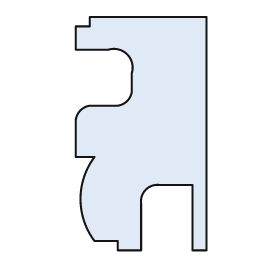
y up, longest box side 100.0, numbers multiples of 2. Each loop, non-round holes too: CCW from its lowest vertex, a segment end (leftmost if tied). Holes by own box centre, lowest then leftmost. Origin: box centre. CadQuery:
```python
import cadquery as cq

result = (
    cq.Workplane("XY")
    .moveTo(-10.0, -50.0)
    .lineTo(0.0, -50.0)
    .lineTo(0.0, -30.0)
    .threePointArc((2.0, -24.0), (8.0, -22.0))
    .lineTo(22.0, -22.0)
    .lineTo(22.0, -50.0)
    .lineTo(28.0, -50.0)
    .lineTo(28.0, 50.0)
    .lineTo(-22.0, 50.0)
    .lineTo(-22.0, 46.0)
    .lineTo(-28.0, 46.0)
    .lineTo(-28.0, 36.0)
    .lineTo(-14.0, 36.0)
    .threePointArc((-6.0, 34.0), (-4.0, 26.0))
    .lineTo(-4.0, 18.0)
    .threePointArc((-6.0, 14.0), (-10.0, 12.0))
    .lineTo(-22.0, 12.0)
    .threePointArc((-26.0, 10.0), (-28.0, 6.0))
    .lineTo(-28.0, -10.0)
    .lineTo(-20.0, -10.0)
    .threePointArc((-26.0, -28.0), (-20.0, -46.0))
    .lineTo(-10.0, -46.0)
    .close()
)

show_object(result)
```